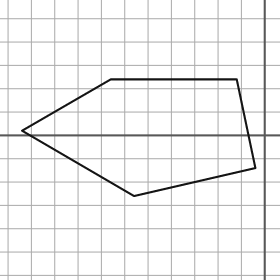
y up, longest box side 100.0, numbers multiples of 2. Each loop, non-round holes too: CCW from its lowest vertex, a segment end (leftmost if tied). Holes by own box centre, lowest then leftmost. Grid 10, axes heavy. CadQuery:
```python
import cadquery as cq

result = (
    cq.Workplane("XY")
    .moveTo(-56.0, -26.0)
    .lineTo(-4.0, -14.0)
    .lineTo(-12.0, 24.0)
    .lineTo(-66.0, 24.0)
    .lineTo(-104.0, 2.0)
    .close()
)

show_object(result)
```